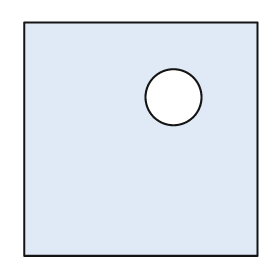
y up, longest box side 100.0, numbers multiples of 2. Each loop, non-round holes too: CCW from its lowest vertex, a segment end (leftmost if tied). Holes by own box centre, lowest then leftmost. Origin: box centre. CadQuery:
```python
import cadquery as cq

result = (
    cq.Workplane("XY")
    .moveTo(-50.0, -50.0)
    .lineTo(50.0, -50.0)
    .lineTo(50.0, 50.0)
    .lineTo(-50.0, 50.0)
    .close()
    .moveTo(14.0, 18.0)
    .circle(12.0)
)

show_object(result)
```